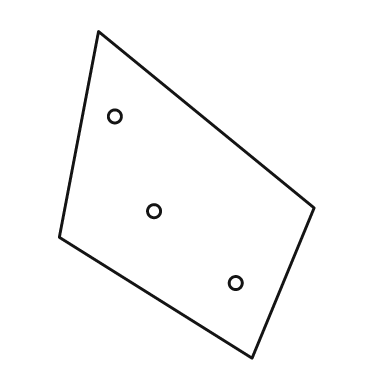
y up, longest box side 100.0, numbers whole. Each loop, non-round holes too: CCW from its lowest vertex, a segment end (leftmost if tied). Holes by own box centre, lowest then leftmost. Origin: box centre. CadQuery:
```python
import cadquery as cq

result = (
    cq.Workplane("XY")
    .moveTo(20.0, -50.0)
    .lineTo(39.0, -4.0)
    .lineTo(-27.0, 50.0)
    .lineTo(-39.0, -13.0)
    .close()
    .moveTo(15.0, -27.0)
    .circle(2.0)
    .moveTo(-10.0, -5.0)
    .circle(2.0)
    .moveTo(-22.0, 24.0)
    .circle(2.0)
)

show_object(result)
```